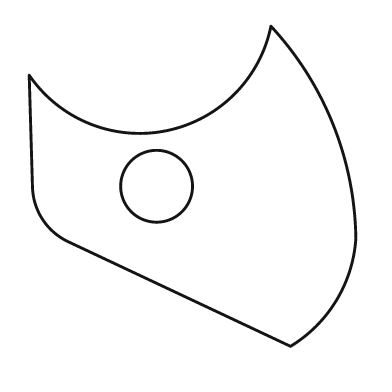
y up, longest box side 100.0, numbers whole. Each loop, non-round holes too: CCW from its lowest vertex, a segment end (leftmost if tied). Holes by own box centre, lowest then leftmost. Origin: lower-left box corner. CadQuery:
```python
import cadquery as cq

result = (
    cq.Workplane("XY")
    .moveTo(80.0, 0.0)
    .threePointArc((94.0, 14.0), (100.0, 33.0))
    .threePointArc((93.0, 68.0), (74.0, 98.0))
    .threePointArc((42.0, 66.0), (0.0, 83.0))
    .lineTo(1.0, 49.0)
    .threePointArc((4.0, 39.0), (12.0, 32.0))
    .close()
    .moveTo(39.0, 49.0)
    .circle(11.0)
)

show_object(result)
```